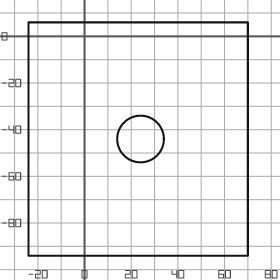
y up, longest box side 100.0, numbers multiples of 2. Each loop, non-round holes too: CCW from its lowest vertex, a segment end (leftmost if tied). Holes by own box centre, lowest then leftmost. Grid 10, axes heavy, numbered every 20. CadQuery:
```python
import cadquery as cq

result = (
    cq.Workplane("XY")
    .moveTo(-24.0, -94.0)
    .lineTo(70.0, -94.0)
    .lineTo(70.0, 6.0)
    .lineTo(-24.0, 6.0)
    .close()
    .moveTo(24.0, -44.0)
    .circle(10.0)
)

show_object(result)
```